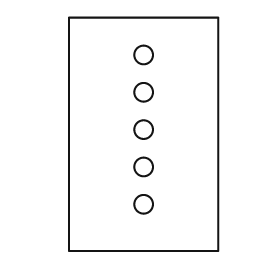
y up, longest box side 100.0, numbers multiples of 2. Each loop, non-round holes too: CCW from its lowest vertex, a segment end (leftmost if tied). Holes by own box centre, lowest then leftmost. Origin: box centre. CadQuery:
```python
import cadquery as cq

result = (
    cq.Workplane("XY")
    .moveTo(-32.0, -50.0)
    .lineTo(32.0, -50.0)
    .lineTo(32.0, 50.0)
    .lineTo(-32.0, 50.0)
    .close()
    .moveTo(0.0, -30.0)
    .circle(4.0)
    .moveTo(0.0, -14.0)
    .circle(4.0)
    .moveTo(0.0, 2.0)
    .circle(4.0)
    .moveTo(0.0, 18.0)
    .circle(4.0)
    .moveTo(0.0, 34.0)
    .circle(4.0)
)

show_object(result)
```